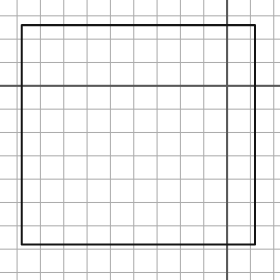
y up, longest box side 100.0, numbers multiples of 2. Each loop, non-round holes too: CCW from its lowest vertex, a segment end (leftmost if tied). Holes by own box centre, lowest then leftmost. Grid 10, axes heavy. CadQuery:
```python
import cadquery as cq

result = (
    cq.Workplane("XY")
    .moveTo(-88.0, -68.0)
    .lineTo(12.0, -68.0)
    .lineTo(12.0, 26.0)
    .lineTo(-88.0, 26.0)
    .close()
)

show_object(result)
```